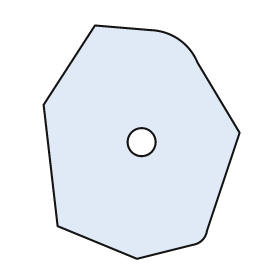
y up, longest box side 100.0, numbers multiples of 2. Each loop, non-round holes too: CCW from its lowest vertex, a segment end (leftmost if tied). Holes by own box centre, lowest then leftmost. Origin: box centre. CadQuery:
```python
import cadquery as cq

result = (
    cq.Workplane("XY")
    .moveTo(-2.0, -50.0)
    .lineTo(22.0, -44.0)
    .threePointArc((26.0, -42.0), (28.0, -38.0))
    .lineTo(42.0, 4.0)
    .lineTo(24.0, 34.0)
    .threePointArc((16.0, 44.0), (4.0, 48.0))
    .lineTo(-20.0, 50.0)
    .lineTo(-42.0, 16.0)
    .lineTo(-36.0, -36.0)
    .close()
    .moveTo(0.0, 0.0)
    .circle(6.0)
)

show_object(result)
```